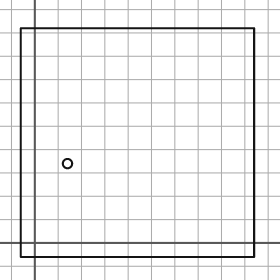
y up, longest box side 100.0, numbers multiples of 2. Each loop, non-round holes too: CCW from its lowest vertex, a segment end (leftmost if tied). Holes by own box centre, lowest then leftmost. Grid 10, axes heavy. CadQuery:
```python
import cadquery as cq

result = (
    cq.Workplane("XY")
    .moveTo(-6.0, -6.0)
    .lineTo(94.0, -6.0)
    .lineTo(94.0, 92.0)
    .lineTo(-6.0, 92.0)
    .close()
    .moveTo(14.0, 34.0)
    .circle(2.0)
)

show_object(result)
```